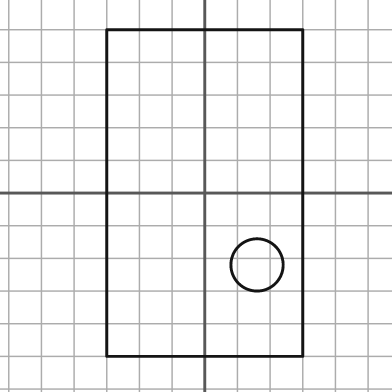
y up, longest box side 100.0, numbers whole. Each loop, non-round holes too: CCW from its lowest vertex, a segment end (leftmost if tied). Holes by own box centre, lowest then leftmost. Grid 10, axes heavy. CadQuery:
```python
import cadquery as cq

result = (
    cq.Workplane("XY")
    .moveTo(-30.0, -50.0)
    .lineTo(30.0, -50.0)
    .lineTo(30.0, 50.0)
    .lineTo(-30.0, 50.0)
    .close()
    .moveTo(16.0, -22.0)
    .circle(8.0)
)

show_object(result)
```